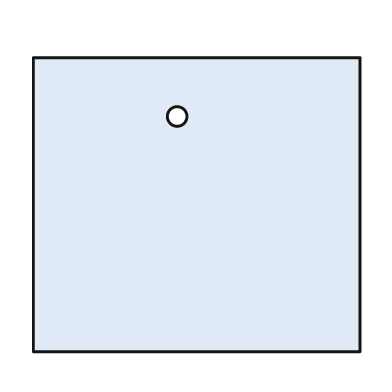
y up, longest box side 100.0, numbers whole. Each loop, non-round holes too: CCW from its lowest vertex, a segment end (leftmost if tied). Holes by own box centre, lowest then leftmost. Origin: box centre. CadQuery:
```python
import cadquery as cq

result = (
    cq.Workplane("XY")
    .moveTo(-50.0, -45.0)
    .lineTo(50.0, -45.0)
    .lineTo(50.0, 45.0)
    .lineTo(-50.0, 45.0)
    .close()
    .moveTo(-6.0, 27.0)
    .circle(3.0)
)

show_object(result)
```